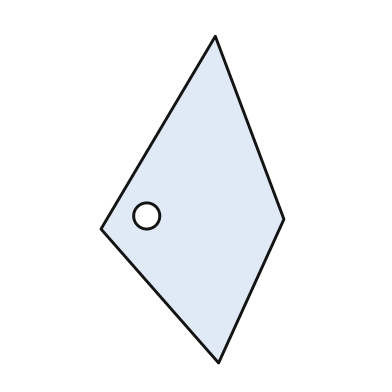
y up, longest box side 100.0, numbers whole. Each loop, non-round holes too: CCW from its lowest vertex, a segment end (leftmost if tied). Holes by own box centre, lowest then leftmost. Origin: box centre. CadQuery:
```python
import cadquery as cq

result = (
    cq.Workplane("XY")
    .moveTo(8.0, -50.0)
    .lineTo(28.0, -6.0)
    .lineTo(7.0, 50.0)
    .lineTo(-28.0, -9.0)
    .close()
    .moveTo(-14.0, -5.0)
    .circle(4.0)
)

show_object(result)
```